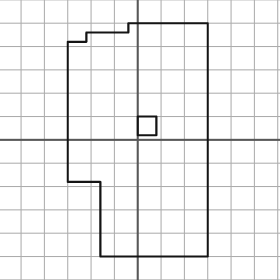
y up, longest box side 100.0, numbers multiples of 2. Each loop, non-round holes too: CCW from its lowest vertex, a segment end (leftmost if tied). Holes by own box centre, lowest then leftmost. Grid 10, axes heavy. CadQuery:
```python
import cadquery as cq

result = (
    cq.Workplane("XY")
    .moveTo(-16.0, -50.0)
    .lineTo(30.0, -50.0)
    .lineTo(30.0, 50.0)
    .lineTo(-4.0, 50.0)
    .lineTo(-4.0, 46.0)
    .lineTo(-22.0, 46.0)
    .lineTo(-22.0, 42.0)
    .lineTo(-30.0, 42.0)
    .lineTo(-30.0, -18.0)
    .lineTo(-16.0, -18.0)
    .close()
    .moveTo(0.0, 2.0)
    .lineTo(8.0, 2.0)
    .lineTo(8.0, 10.0)
    .lineTo(0.0, 10.0)
    .close()
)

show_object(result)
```